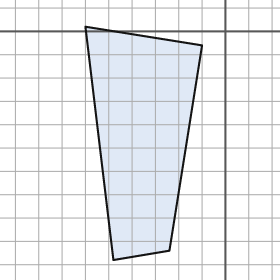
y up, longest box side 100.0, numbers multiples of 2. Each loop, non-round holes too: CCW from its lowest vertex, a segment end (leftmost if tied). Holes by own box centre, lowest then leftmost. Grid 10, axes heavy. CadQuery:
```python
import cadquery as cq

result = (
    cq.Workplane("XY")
    .moveTo(-48.0, -98.0)
    .lineTo(-24.0, -94.0)
    .lineTo(-10.0, -6.0)
    .lineTo(-60.0, 2.0)
    .close()
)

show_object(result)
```